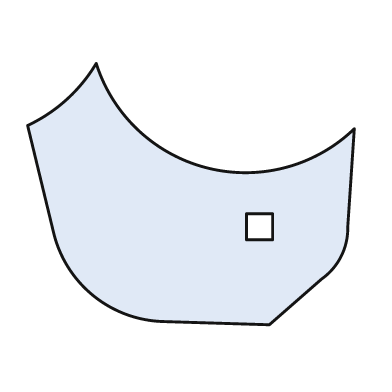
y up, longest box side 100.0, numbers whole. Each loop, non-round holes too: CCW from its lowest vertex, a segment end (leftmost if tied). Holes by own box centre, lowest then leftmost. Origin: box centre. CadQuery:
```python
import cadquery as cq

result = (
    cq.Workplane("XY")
    .moveTo(24.0, -40.0)
    .lineTo(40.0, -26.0)
    .threePointArc((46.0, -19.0), (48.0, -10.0))
    .lineTo(50.0, 20.0)
    .threePointArc((5.0, 8.0), (-29.0, 40.0))
    .threePointArc((-38.0, 29.0), (-50.0, 21.0))
    .lineTo(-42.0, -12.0)
    .threePointArc((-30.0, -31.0), (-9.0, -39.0))
    .close()
    .moveTo(17.0, -14.0)
    .lineTo(25.0, -14.0)
    .lineTo(25.0, -6.0)
    .lineTo(17.0, -6.0)
    .close()
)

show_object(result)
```